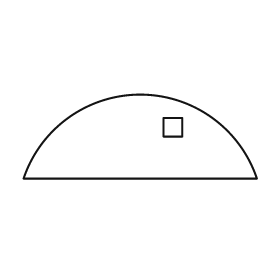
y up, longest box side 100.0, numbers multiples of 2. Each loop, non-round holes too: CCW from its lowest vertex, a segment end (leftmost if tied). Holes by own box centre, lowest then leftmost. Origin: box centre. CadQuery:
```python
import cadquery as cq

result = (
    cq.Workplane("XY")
    .moveTo(-50.0, -18.0)
    .lineTo(50.0, -18.0)
    .threePointArc((0.0, 18.0), (-50.0, -18.0))
    .close()
    .moveTo(10.0, 0.0)
    .lineTo(18.0, 0.0)
    .lineTo(18.0, 8.0)
    .lineTo(10.0, 8.0)
    .close()
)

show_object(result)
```